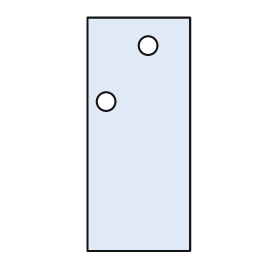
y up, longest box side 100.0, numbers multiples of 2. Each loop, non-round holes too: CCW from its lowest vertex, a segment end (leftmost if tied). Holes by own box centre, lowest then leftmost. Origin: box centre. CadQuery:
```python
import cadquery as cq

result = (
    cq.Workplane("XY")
    .moveTo(-22.0, -50.0)
    .lineTo(22.0, -50.0)
    .lineTo(22.0, 50.0)
    .lineTo(-22.0, 50.0)
    .close()
    .moveTo(-14.0, 14.0)
    .circle(4.0)
    .moveTo(4.0, 38.0)
    .circle(4.0)
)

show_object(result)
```